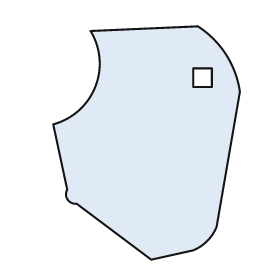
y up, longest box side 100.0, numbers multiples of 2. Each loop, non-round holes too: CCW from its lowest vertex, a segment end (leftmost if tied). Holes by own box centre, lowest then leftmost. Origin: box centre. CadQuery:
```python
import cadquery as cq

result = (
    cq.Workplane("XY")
    .moveTo(2.0, -50.0)
    .lineTo(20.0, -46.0)
    .threePointArc((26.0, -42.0), (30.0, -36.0))
    .lineTo(40.0, 22.0)
    .threePointArc((34.0, 38.0), (22.0, 50.0))
    .lineTo(-24.0, 48.0)
    .threePointArc((-22.0, 24.0), (-40.0, 8.0))
    .lineTo(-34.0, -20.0)
    .threePointArc((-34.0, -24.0), (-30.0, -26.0))
    .close()
    .moveTo(20.0, 24.0)
    .lineTo(28.0, 24.0)
    .lineTo(28.0, 32.0)
    .lineTo(20.0, 32.0)
    .close()
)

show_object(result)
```